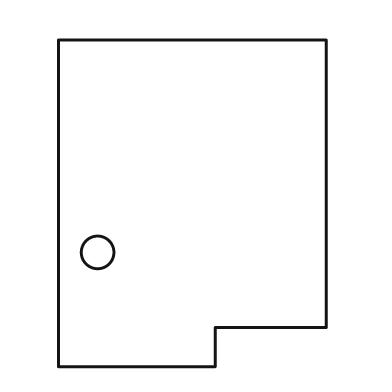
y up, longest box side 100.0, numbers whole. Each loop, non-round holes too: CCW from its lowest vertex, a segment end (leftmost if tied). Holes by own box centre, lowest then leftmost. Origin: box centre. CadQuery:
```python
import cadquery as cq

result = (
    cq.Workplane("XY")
    .moveTo(-41.0, -50.0)
    .lineTo(7.0, -50.0)
    .lineTo(7.0, -38.0)
    .lineTo(41.0, -38.0)
    .lineTo(41.0, 50.0)
    .lineTo(-41.0, 50.0)
    .close()
    .moveTo(-29.0, -15.0)
    .circle(5.0)
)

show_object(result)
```